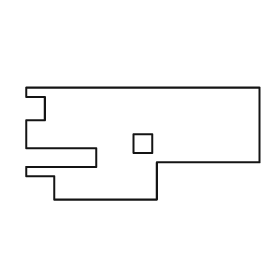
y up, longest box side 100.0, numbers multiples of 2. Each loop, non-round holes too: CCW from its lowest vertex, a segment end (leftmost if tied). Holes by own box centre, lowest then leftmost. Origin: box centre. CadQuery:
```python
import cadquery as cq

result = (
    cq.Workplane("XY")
    .moveTo(-38.0, -24.0)
    .lineTo(6.0, -24.0)
    .lineTo(6.0, -8.0)
    .lineTo(50.0, -8.0)
    .lineTo(50.0, 24.0)
    .lineTo(-50.0, 24.0)
    .lineTo(-50.0, 20.0)
    .lineTo(-42.0, 20.0)
    .lineTo(-42.0, 10.0)
    .lineTo(-50.0, 10.0)
    .lineTo(-50.0, -2.0)
    .lineTo(-20.0, -2.0)
    .lineTo(-20.0, -10.0)
    .lineTo(-50.0, -10.0)
    .lineTo(-50.0, -14.0)
    .lineTo(-38.0, -14.0)
    .close()
    .moveTo(-4.0, -4.0)
    .lineTo(4.0, -4.0)
    .lineTo(4.0, 4.0)
    .lineTo(-4.0, 4.0)
    .close()
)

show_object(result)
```